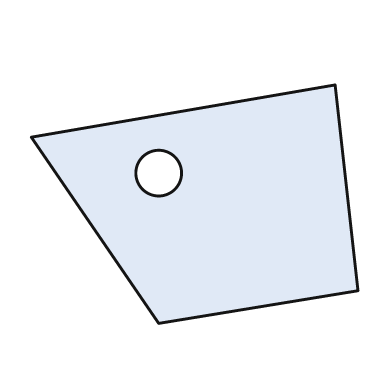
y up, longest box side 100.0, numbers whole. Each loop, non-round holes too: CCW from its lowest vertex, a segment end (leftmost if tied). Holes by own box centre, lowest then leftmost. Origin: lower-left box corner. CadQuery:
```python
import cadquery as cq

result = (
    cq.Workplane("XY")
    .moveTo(39.0, 0.0)
    .lineTo(100.0, 10.0)
    .lineTo(93.0, 73.0)
    .lineTo(0.0, 57.0)
    .close()
    .moveTo(39.0, 46.0)
    .circle(7.0)
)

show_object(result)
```